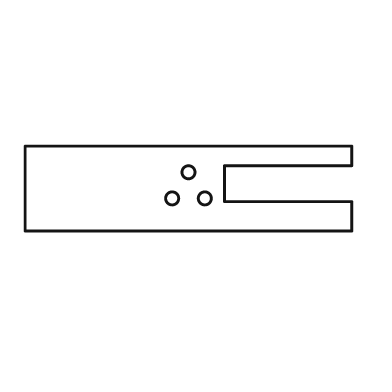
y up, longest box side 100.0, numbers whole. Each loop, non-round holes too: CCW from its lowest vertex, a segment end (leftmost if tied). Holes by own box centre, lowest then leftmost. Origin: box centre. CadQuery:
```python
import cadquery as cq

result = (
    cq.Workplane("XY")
    .moveTo(-50.0, -13.0)
    .lineTo(50.0, -13.0)
    .lineTo(50.0, -4.0)
    .lineTo(11.0, -4.0)
    .lineTo(11.0, 7.0)
    .lineTo(50.0, 7.0)
    .lineTo(50.0, 13.0)
    .lineTo(-50.0, 13.0)
    .close()
    .moveTo(-5.0, -3.0)
    .circle(2.0)
    .moveTo(5.0, -3.0)
    .circle(2.0)
    .moveTo(0.0, 5.0)
    .circle(2.0)
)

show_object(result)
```